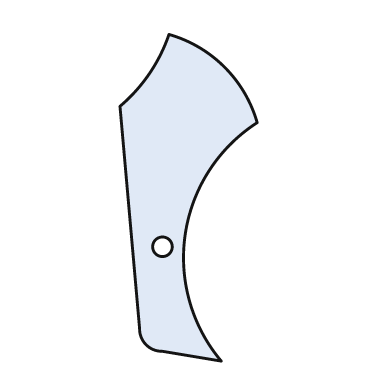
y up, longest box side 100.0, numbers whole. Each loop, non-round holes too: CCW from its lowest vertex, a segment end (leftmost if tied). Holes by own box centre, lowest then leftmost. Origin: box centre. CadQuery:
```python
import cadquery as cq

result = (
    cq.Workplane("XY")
    .moveTo(10.0, -50.0)
    .threePointArc((-1.0, -11.0), (21.0, 23.0))
    .threePointArc((11.0, 40.0), (-6.0, 50.0))
    .threePointArc((-12.0, 38.0), (-21.0, 28.0))
    .lineTo(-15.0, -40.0)
    .threePointArc((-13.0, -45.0), (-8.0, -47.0))
    .close()
    .moveTo(-8.0, -15.0)
    .circle(3.0)
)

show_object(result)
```